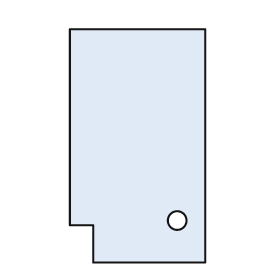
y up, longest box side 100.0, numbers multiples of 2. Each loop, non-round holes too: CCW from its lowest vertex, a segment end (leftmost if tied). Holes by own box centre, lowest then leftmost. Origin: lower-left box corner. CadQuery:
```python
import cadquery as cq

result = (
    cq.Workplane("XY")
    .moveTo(10.0, 0.0)
    .lineTo(58.0, 0.0)
    .lineTo(58.0, 100.0)
    .lineTo(0.0, 100.0)
    .lineTo(0.0, 16.0)
    .lineTo(10.0, 16.0)
    .close()
    .moveTo(46.0, 18.0)
    .circle(4.0)
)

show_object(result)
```